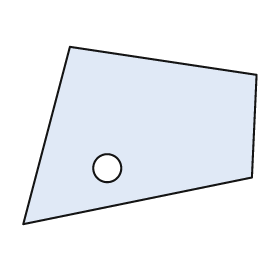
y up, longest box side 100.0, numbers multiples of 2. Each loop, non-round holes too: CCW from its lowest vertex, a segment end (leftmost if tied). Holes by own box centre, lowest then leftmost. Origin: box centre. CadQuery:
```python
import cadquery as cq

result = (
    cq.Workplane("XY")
    .moveTo(-50.0, -38.0)
    .lineTo(48.0, -18.0)
    .lineTo(50.0, 26.0)
    .lineTo(-30.0, 38.0)
    .close()
    .moveTo(-14.0, -14.0)
    .circle(6.0)
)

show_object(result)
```